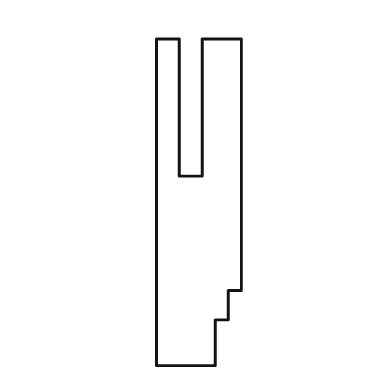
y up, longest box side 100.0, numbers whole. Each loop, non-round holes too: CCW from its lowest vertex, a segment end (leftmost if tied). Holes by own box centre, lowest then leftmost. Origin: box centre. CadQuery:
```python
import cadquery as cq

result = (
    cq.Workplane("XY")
    .moveTo(-13.0, -50.0)
    .lineTo(5.0, -50.0)
    .lineTo(5.0, -36.0)
    .lineTo(9.0, -36.0)
    .lineTo(9.0, -27.0)
    .lineTo(13.0, -27.0)
    .lineTo(13.0, 50.0)
    .lineTo(1.0, 50.0)
    .lineTo(1.0, 8.0)
    .lineTo(-6.0, 8.0)
    .lineTo(-6.0, 50.0)
    .lineTo(-13.0, 50.0)
    .close()
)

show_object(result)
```